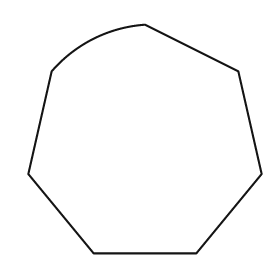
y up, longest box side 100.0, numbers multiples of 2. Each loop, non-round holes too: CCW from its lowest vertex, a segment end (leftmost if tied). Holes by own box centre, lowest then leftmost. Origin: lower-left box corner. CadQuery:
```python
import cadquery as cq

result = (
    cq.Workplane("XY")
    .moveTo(28.0, 0.0)
    .lineTo(72.0, 0.0)
    .lineTo(100.0, 34.0)
    .lineTo(90.0, 78.0)
    .lineTo(50.0, 98.0)
    .threePointArc((28.0, 92.0), (10.0, 78.0))
    .lineTo(0.0, 34.0)
    .close()
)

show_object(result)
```